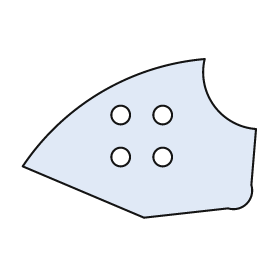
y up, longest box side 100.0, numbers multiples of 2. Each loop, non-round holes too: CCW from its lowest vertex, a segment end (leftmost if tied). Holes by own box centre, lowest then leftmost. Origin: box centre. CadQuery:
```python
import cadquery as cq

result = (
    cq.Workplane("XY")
    .moveTo(2.0, -34.0)
    .lineTo(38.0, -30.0)
    .threePointArc((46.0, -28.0), (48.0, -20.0))
    .lineTo(50.0, 4.0)
    .threePointArc((32.0, 14.0), (28.0, 34.0))
    .threePointArc((-16.0, 20.0), (-50.0, -12.0))
    .close()
    .moveTo(-8.0, -8.0)
    .circle(4.0)
    .moveTo(10.0, -8.0)
    .circle(4.0)
    .moveTo(-8.0, 10.0)
    .circle(4.0)
    .moveTo(10.0, 10.0)
    .circle(4.0)
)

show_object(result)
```